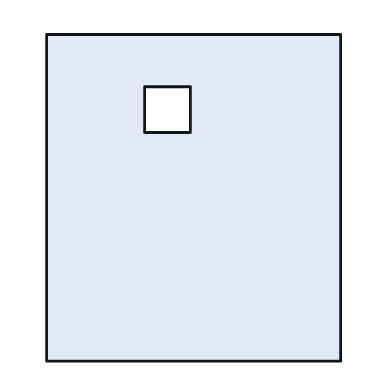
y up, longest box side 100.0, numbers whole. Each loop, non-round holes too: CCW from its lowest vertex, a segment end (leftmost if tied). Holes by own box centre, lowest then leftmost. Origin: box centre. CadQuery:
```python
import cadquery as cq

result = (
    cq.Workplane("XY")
    .moveTo(-45.0, -50.0)
    .lineTo(45.0, -50.0)
    .lineTo(45.0, 50.0)
    .lineTo(-45.0, 50.0)
    .close()
    .moveTo(-15.0, 20.0)
    .lineTo(-1.0, 20.0)
    .lineTo(-1.0, 34.0)
    .lineTo(-15.0, 34.0)
    .close()
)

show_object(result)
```